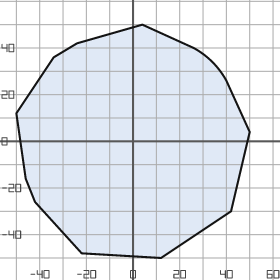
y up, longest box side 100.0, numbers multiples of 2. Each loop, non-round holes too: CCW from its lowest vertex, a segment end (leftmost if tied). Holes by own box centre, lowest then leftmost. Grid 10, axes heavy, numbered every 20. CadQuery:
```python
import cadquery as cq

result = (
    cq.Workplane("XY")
    .moveTo(12.0, -50.0)
    .lineTo(42.0, -30.0)
    .lineTo(50.0, 4.0)
    .lineTo(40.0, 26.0)
    .threePointArc((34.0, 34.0), (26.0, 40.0))
    .lineTo(4.0, 50.0)
    .lineTo(-24.0, 42.0)
    .lineTo(-34.0, 36.0)
    .lineTo(-50.0, 12.0)
    .lineTo(-46.0, -16.0)
    .lineTo(-42.0, -26.0)
    .lineTo(-22.0, -48.0)
    .close()
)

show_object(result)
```